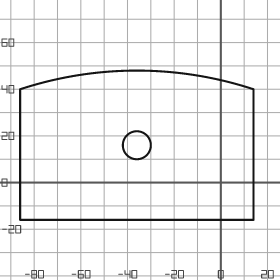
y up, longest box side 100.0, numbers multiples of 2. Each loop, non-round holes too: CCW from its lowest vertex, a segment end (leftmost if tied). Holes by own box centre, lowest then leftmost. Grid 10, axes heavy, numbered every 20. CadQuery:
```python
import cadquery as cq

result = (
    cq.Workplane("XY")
    .moveTo(-86.0, -16.0)
    .lineTo(14.0, -16.0)
    .lineTo(14.0, 40.0)
    .threePointArc((-36.0, 48.0), (-86.0, 40.0))
    .close()
    .moveTo(-36.0, 16.0)
    .circle(6.0)
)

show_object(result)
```